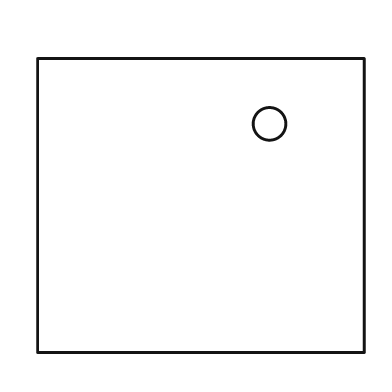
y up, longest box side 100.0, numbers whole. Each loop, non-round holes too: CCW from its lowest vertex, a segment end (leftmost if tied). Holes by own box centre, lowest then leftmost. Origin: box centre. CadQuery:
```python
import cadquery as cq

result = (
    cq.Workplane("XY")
    .moveTo(-50.0, -45.0)
    .lineTo(50.0, -45.0)
    .lineTo(50.0, 45.0)
    .lineTo(-50.0, 45.0)
    .close()
    .moveTo(21.0, 25.0)
    .circle(5.0)
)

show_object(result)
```